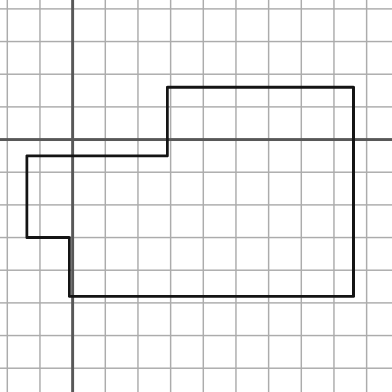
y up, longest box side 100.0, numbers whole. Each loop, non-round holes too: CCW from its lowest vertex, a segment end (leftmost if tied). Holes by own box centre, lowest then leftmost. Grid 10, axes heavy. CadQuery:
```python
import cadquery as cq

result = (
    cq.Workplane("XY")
    .moveTo(-1.0, -48.0)
    .lineTo(86.0, -48.0)
    .lineTo(86.0, 16.0)
    .lineTo(29.0, 16.0)
    .lineTo(29.0, -5.0)
    .lineTo(-14.0, -5.0)
    .lineTo(-14.0, -30.0)
    .lineTo(-1.0, -30.0)
    .close()
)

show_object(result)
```